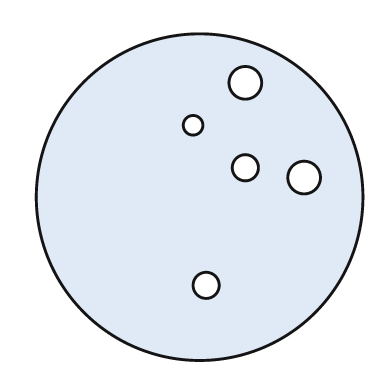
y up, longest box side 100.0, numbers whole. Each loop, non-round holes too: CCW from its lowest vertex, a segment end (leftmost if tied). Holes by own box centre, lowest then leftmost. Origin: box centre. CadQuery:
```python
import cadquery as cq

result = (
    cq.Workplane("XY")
    .moveTo(0.0, 0.0)
    .circle(50.0)
    .moveTo(2.0, -27.0)
    .circle(4.0)
    .moveTo(32.0, 6.0)
    .circle(5.0)
    .moveTo(14.0, 9.0)
    .circle(4.0)
    .moveTo(-2.0, 22.0)
    .circle(3.0)
    .moveTo(14.0, 35.0)
    .circle(5.0)
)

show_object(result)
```